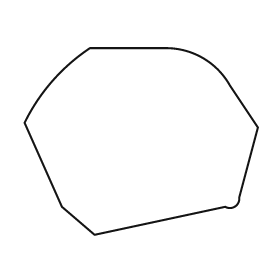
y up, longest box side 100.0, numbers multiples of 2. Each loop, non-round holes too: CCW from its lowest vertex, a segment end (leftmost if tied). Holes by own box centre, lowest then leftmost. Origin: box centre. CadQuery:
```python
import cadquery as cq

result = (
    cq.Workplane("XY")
    .moveTo(-20.0, -40.0)
    .lineTo(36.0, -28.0)
    .threePointArc((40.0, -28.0), (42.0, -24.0))
    .lineTo(50.0, 6.0)
    .lineTo(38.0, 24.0)
    .threePointArc((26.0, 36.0), (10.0, 40.0))
    .lineTo(-22.0, 40.0)
    .threePointArc((-38.0, 26.0), (-50.0, 8.0))
    .lineTo(-34.0, -28.0)
    .close()
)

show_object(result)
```